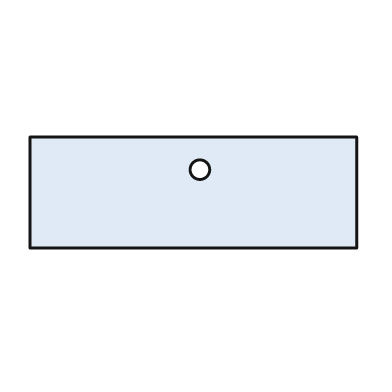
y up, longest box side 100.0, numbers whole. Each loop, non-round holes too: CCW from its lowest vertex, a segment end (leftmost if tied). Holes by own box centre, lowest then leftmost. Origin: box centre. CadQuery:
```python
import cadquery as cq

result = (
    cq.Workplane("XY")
    .moveTo(-50.0, -17.0)
    .lineTo(50.0, -17.0)
    .lineTo(50.0, 17.0)
    .lineTo(-50.0, 17.0)
    .close()
    .moveTo(2.0, 7.0)
    .circle(3.0)
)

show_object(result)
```